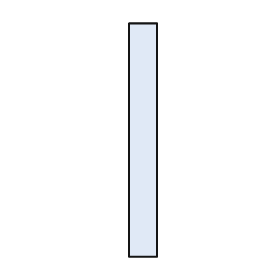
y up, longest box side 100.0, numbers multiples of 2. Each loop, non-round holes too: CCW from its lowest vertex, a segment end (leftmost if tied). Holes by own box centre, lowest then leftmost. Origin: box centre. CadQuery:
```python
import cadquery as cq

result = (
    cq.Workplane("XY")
    .moveTo(-6.0, -50.0)
    .lineTo(6.0, -50.0)
    .lineTo(6.0, 50.0)
    .lineTo(-6.0, 50.0)
    .close()
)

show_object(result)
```